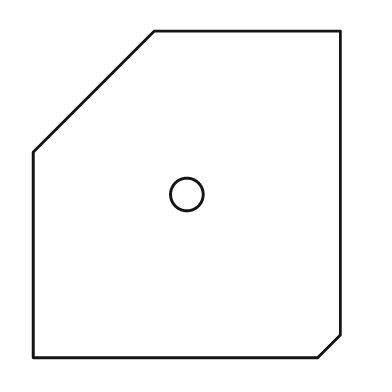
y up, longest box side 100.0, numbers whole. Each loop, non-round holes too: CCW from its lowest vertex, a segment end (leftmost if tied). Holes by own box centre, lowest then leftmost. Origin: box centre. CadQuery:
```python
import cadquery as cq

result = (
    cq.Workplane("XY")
    .moveTo(-47.0, -50.0)
    .lineTo(40.0, -50.0)
    .lineTo(47.0, -43.0)
    .lineTo(47.0, 50.0)
    .lineTo(-10.0, 50.0)
    .lineTo(-47.0, 13.0)
    .close()
    .moveTo(0.0, 0.0)
    .circle(5.0)
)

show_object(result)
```